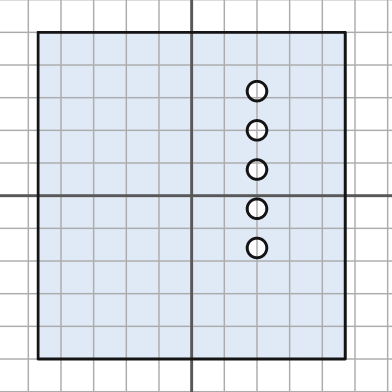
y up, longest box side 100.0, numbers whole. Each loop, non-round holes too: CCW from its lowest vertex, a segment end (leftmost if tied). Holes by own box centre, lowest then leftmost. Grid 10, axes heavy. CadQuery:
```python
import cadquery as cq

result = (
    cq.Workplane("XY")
    .moveTo(-47.0, -50.0)
    .lineTo(47.0, -50.0)
    .lineTo(47.0, 50.0)
    .lineTo(-47.0, 50.0)
    .close()
    .moveTo(20.0, -16.0)
    .circle(3.0)
    .moveTo(20.0, -4.0)
    .circle(3.0)
    .moveTo(20.0, 8.0)
    .circle(3.0)
    .moveTo(20.0, 20.0)
    .circle(3.0)
    .moveTo(20.0, 32.0)
    .circle(3.0)
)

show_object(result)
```